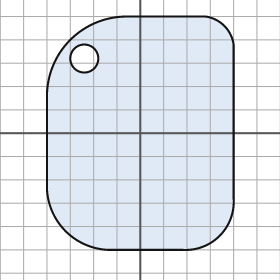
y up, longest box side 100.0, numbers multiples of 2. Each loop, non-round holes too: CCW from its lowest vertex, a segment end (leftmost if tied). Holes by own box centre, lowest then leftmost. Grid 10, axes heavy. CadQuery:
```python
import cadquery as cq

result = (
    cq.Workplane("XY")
    .moveTo(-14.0, -50.0)
    .lineTo(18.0, -50.0)
    .threePointArc((34.0, -44.0), (40.0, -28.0))
    .lineTo(40.0, 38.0)
    .threePointArc((36.0, 46.0), (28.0, 50.0))
    .lineTo(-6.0, 50.0)
    .threePointArc((-30.0, 40.0), (-40.0, 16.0))
    .lineTo(-40.0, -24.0)
    .threePointArc((-32.0, -42.0), (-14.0, -50.0))
    .close()
    .moveTo(-24.0, 32.0)
    .circle(6.0)
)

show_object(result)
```